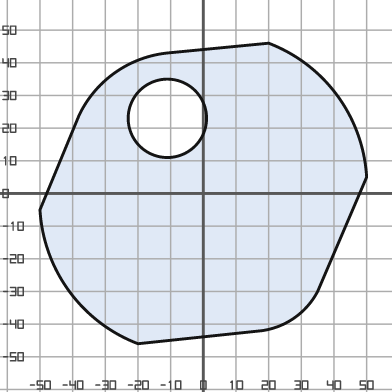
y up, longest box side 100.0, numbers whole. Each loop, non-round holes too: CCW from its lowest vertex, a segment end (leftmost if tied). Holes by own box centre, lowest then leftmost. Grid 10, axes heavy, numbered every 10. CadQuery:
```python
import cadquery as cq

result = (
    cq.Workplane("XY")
    .moveTo(-20.0, -46.0)
    .lineTo(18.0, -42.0)
    .threePointArc((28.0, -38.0), (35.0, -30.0))
    .lineTo(50.0, 5.0)
    .threePointArc((41.0, 30.0), (20.0, 46.0))
    .lineTo(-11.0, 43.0)
    .threePointArc((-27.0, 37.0), (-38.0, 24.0))
    .lineTo(-50.0, -5.0)
    .threePointArc((-41.0, -30.0), (-20.0, -46.0))
    .close()
    .moveTo(-11.0, 23.0)
    .circle(12.0)
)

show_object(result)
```